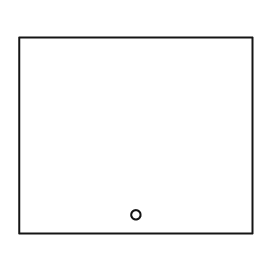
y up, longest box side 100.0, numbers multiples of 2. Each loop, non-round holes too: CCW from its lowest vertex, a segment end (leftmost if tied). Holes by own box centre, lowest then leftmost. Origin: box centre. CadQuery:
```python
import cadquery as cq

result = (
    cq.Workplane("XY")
    .moveTo(-50.0, -42.0)
    .lineTo(50.0, -42.0)
    .lineTo(50.0, 42.0)
    .lineTo(-50.0, 42.0)
    .close()
    .moveTo(0.0, -34.0)
    .circle(2.0)
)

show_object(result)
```